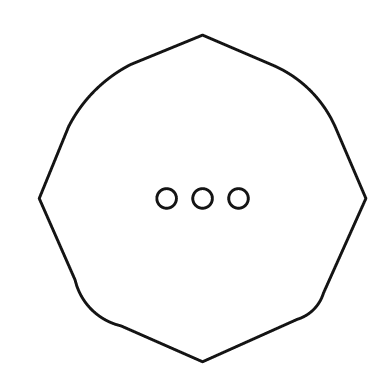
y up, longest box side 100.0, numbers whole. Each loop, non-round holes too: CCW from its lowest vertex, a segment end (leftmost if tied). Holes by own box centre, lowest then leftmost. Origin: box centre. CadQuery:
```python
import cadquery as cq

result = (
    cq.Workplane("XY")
    .moveTo(0.0, -50.0)
    .lineTo(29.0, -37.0)
    .threePointArc((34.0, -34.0), (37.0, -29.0))
    .lineTo(50.0, 0.0)
    .lineTo(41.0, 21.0)
    .threePointArc((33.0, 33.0), (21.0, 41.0))
    .lineTo(0.0, 50.0)
    .lineTo(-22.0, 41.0)
    .threePointArc((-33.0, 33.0), (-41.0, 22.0))
    .lineTo(-50.0, 0.0)
    .lineTo(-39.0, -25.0)
    .threePointArc((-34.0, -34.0), (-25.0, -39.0))
    .close()
    .moveTo(-11.0, 0.0)
    .circle(3.0)
    .moveTo(0.0, 0.0)
    .circle(3.0)
    .moveTo(11.0, 0.0)
    .circle(3.0)
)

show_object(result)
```